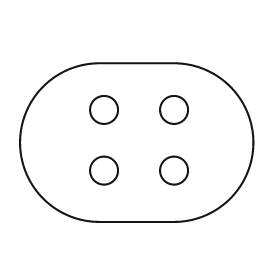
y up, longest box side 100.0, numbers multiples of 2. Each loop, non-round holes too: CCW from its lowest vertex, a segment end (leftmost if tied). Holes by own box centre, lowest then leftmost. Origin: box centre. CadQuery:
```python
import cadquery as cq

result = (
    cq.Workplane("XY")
    .moveTo(-16.0, -34.0)
    .lineTo(16.0, -34.0)
    .threePointArc((50.0, 0.0), (16.0, 34.0))
    .lineTo(-16.0, 34.0)
    .threePointArc((-50.0, 0.0), (-16.0, -34.0))
    .close()
    .moveTo(-14.0, -12.0)
    .circle(6.0)
    .moveTo(16.0, -12.0)
    .circle(6.0)
    .moveTo(-14.0, 14.0)
    .circle(6.0)
    .moveTo(16.0, 14.0)
    .circle(6.0)
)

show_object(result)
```